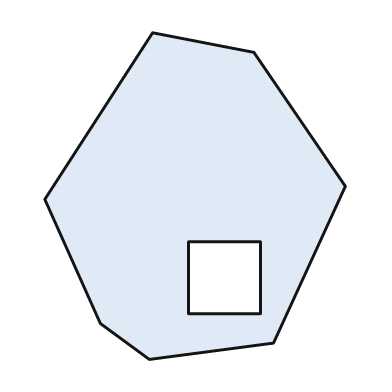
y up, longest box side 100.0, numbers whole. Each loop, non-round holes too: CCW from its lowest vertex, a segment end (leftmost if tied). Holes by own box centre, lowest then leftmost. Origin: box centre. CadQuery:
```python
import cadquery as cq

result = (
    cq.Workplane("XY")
    .moveTo(-14.0, -50.0)
    .lineTo(24.0, -45.0)
    .lineTo(46.0, 3.0)
    .lineTo(18.0, 44.0)
    .lineTo(-13.0, 50.0)
    .lineTo(-46.0, -1.0)
    .lineTo(-29.0, -39.0)
    .close()
    .moveTo(-2.0, -36.0)
    .lineTo(20.0, -36.0)
    .lineTo(20.0, -14.0)
    .lineTo(-2.0, -14.0)
    .close()
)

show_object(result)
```